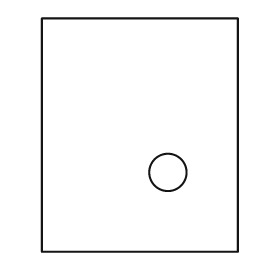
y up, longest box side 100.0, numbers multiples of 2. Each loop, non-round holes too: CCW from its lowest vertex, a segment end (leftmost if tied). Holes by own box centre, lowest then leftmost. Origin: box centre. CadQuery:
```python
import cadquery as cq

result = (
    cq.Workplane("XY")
    .moveTo(-42.0, -50.0)
    .lineTo(42.0, -50.0)
    .lineTo(42.0, 50.0)
    .lineTo(-42.0, 50.0)
    .close()
    .moveTo(12.0, -16.0)
    .circle(8.0)
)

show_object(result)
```